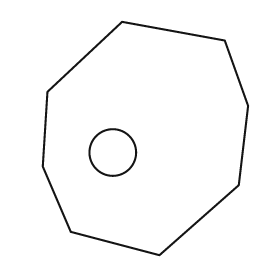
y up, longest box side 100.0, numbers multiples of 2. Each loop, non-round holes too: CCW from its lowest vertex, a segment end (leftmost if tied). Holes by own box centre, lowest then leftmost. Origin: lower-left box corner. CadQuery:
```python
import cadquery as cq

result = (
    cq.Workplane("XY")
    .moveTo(50.0, 0.0)
    .lineTo(84.0, 30.0)
    .lineTo(88.0, 64.0)
    .lineTo(78.0, 92.0)
    .lineTo(34.0, 100.0)
    .lineTo(2.0, 70.0)
    .lineTo(0.0, 38.0)
    .lineTo(12.0, 10.0)
    .close()
    .moveTo(30.0, 44.0)
    .circle(10.0)
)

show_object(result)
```